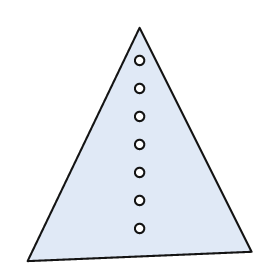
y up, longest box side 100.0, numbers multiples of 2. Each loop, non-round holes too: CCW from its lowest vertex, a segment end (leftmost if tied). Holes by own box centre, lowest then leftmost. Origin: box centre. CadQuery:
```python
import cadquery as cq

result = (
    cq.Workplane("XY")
    .moveTo(-48.0, -50.0)
    .lineTo(48.0, -46.0)
    .lineTo(0.0, 50.0)
    .close()
    .moveTo(0.0, -36.0)
    .circle(2.0)
    .moveTo(0.0, -24.0)
    .circle(2.0)
    .moveTo(0.0, -12.0)
    .circle(2.0)
    .moveTo(0.0, 0.0)
    .circle(2.0)
    .moveTo(0.0, 12.0)
    .circle(2.0)
    .moveTo(0.0, 24.0)
    .circle(2.0)
    .moveTo(0.0, 36.0)
    .circle(2.0)
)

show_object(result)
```